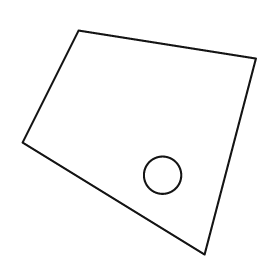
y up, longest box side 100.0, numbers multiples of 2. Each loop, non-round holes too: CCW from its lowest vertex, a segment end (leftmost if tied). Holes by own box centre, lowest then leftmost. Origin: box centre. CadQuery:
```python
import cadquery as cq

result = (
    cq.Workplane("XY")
    .moveTo(28.0, -48.0)
    .lineTo(50.0, 36.0)
    .lineTo(-26.0, 48.0)
    .lineTo(-50.0, 0.0)
    .close()
    .moveTo(10.0, -14.0)
    .circle(8.0)
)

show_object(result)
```